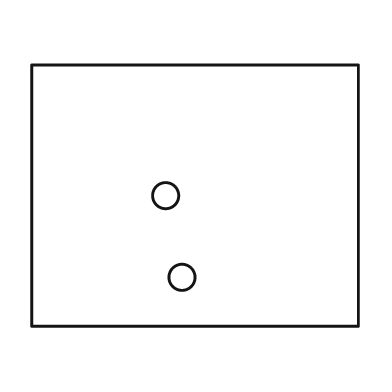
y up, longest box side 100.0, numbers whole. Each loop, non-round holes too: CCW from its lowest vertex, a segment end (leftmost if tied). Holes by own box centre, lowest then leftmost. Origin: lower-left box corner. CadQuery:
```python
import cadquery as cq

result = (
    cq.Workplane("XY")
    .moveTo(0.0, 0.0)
    .lineTo(100.0, 0.0)
    .lineTo(100.0, 80.0)
    .lineTo(0.0, 80.0)
    .close()
    .moveTo(46.0, 15.0)
    .circle(4.0)
    .moveTo(41.0, 40.0)
    .circle(4.0)
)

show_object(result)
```